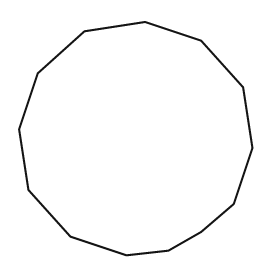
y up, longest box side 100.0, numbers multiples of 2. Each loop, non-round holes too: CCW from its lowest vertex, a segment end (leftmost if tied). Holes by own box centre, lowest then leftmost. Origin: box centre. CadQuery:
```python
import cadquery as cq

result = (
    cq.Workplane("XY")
    .moveTo(-4.0, -50.0)
    .lineTo(14.0, -48.0)
    .lineTo(28.0, -40.0)
    .lineTo(42.0, -28.0)
    .lineTo(50.0, -4.0)
    .lineTo(46.0, 22.0)
    .lineTo(28.0, 42.0)
    .lineTo(4.0, 50.0)
    .lineTo(-22.0, 46.0)
    .lineTo(-42.0, 28.0)
    .lineTo(-50.0, 4.0)
    .lineTo(-46.0, -22.0)
    .lineTo(-28.0, -42.0)
    .close()
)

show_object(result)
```